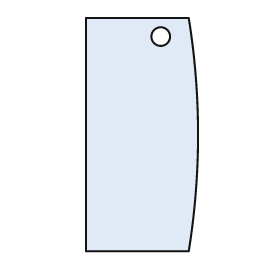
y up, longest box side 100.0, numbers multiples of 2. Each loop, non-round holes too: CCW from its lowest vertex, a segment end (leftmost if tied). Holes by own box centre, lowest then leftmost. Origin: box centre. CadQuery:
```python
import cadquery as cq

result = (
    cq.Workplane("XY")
    .moveTo(-24.0, -50.0)
    .lineTo(20.0, -50.0)
    .threePointArc((24.0, 0.0), (20.0, 50.0))
    .lineTo(-24.0, 50.0)
    .close()
    .moveTo(8.0, 42.0)
    .circle(4.0)
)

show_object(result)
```